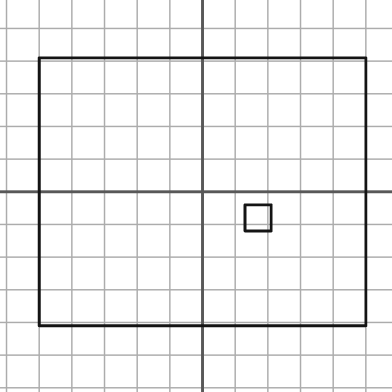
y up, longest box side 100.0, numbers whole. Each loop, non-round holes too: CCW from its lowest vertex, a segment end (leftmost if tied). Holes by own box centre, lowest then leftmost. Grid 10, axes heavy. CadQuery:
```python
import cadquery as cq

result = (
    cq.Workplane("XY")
    .moveTo(-50.0, -41.0)
    .lineTo(50.0, -41.0)
    .lineTo(50.0, 41.0)
    .lineTo(-50.0, 41.0)
    .close()
    .moveTo(13.0, -12.0)
    .lineTo(21.0, -12.0)
    .lineTo(21.0, -4.0)
    .lineTo(13.0, -4.0)
    .close()
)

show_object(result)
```